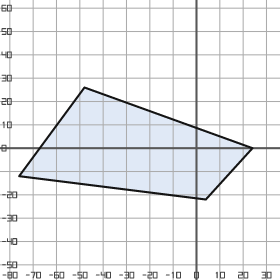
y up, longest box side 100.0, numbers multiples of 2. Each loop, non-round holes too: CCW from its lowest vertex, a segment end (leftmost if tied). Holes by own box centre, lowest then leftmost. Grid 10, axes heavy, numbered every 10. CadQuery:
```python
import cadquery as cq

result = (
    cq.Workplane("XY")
    .moveTo(4.0, -22.0)
    .lineTo(24.0, 0.0)
    .lineTo(-48.0, 26.0)
    .lineTo(-76.0, -12.0)
    .close()
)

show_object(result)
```